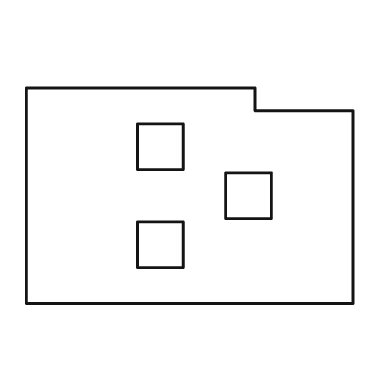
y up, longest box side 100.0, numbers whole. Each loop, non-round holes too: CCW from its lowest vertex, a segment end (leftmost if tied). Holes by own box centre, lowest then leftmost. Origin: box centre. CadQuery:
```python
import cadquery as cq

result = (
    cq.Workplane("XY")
    .moveTo(-50.0, -33.0)
    .lineTo(50.0, -33.0)
    .lineTo(50.0, 26.0)
    .lineTo(20.0, 26.0)
    .lineTo(20.0, 33.0)
    .lineTo(-50.0, 33.0)
    .close()
    .moveTo(-16.0, -22.0)
    .lineTo(-2.0, -22.0)
    .lineTo(-2.0, -8.0)
    .lineTo(-16.0, -8.0)
    .close()
    .moveTo(11.0, -7.0)
    .lineTo(25.0, -7.0)
    .lineTo(25.0, 7.0)
    .lineTo(11.0, 7.0)
    .close()
    .moveTo(-16.0, 8.0)
    .lineTo(-2.0, 8.0)
    .lineTo(-2.0, 22.0)
    .lineTo(-16.0, 22.0)
    .close()
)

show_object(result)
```